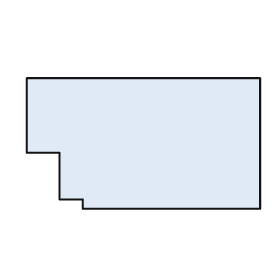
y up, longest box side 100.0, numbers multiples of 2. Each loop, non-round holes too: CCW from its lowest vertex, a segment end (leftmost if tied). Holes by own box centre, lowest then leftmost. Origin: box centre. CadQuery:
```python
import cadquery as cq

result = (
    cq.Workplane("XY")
    .moveTo(-26.0, -28.0)
    .lineTo(50.0, -28.0)
    .lineTo(50.0, 28.0)
    .lineTo(-50.0, 28.0)
    .lineTo(-50.0, -4.0)
    .lineTo(-36.0, -4.0)
    .lineTo(-36.0, -24.0)
    .lineTo(-26.0, -24.0)
    .close()
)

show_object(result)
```